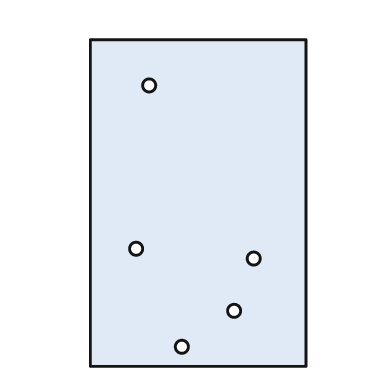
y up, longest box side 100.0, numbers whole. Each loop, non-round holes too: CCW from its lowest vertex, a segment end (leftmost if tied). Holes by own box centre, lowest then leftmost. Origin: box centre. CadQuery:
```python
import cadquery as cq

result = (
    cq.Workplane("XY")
    .moveTo(-33.0, -50.0)
    .lineTo(33.0, -50.0)
    .lineTo(33.0, 50.0)
    .lineTo(-33.0, 50.0)
    .close()
    .moveTo(-5.0, -44.0)
    .circle(2.0)
    .moveTo(11.0, -33.0)
    .circle(2.0)
    .moveTo(17.0, -17.0)
    .circle(2.0)
    .moveTo(-19.0, -14.0)
    .circle(2.0)
    .moveTo(-15.0, 36.0)
    .circle(2.0)
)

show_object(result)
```